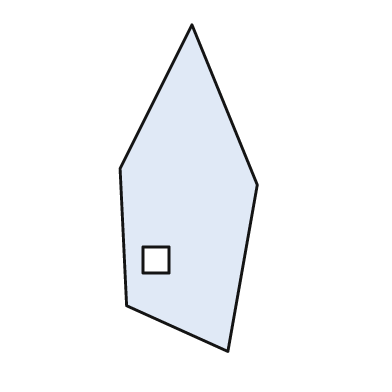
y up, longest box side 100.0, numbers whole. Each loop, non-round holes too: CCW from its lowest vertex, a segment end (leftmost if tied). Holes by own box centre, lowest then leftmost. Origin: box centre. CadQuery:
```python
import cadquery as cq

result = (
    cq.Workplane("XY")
    .moveTo(12.0, -50.0)
    .lineTo(21.0, 1.0)
    .lineTo(1.0, 50.0)
    .lineTo(-21.0, 6.0)
    .lineTo(-19.0, -36.0)
    .close()
    .moveTo(-14.0, -26.0)
    .lineTo(-6.0, -26.0)
    .lineTo(-6.0, -18.0)
    .lineTo(-14.0, -18.0)
    .close()
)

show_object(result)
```